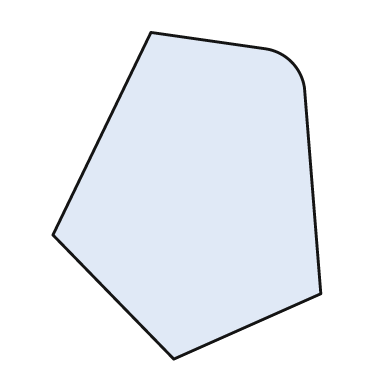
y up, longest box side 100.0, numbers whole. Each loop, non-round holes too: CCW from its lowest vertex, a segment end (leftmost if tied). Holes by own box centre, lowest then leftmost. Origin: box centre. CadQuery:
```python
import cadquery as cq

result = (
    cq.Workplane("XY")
    .moveTo(-4.0, -50.0)
    .lineTo(41.0, -30.0)
    .lineTo(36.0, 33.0)
    .threePointArc((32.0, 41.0), (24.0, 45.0))
    .lineTo(-11.0, 50.0)
    .lineTo(-41.0, -12.0)
    .close()
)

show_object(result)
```